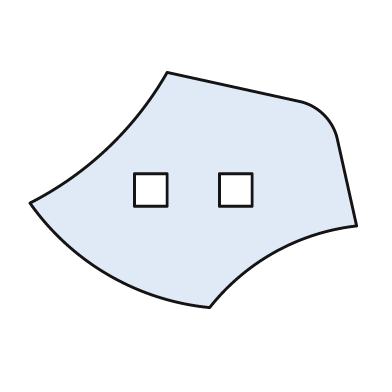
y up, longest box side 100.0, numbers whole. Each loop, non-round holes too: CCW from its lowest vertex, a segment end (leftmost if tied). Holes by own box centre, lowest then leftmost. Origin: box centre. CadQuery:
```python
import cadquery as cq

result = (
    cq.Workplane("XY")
    .moveTo(5.0, -36.0)
    .threePointArc((25.0, -19.0), (50.0, -11.0))
    .lineTo(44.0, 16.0)
    .threePointArc((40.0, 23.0), (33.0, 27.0))
    .lineTo(-8.0, 36.0)
    .threePointArc((-26.0, 13.0), (-50.0, -4.0))
    .threePointArc((-26.0, -26.0), (5.0, -36.0))
    .close()
    .moveTo(-18.0, -5.0)
    .lineTo(-8.0, -5.0)
    .lineTo(-8.0, 5.0)
    .lineTo(-18.0, 5.0)
    .close()
    .moveTo(8.0, -5.0)
    .lineTo(18.0, -5.0)
    .lineTo(18.0, 5.0)
    .lineTo(8.0, 5.0)
    .close()
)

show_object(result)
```